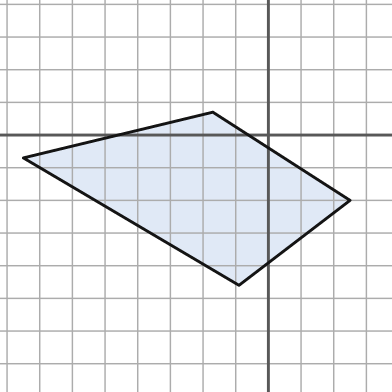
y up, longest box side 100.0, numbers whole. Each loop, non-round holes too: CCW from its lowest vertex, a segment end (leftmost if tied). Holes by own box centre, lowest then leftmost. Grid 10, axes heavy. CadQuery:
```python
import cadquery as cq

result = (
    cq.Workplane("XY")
    .moveTo(-9.0, -46.0)
    .lineTo(25.0, -20.0)
    .lineTo(-17.0, 7.0)
    .lineTo(-75.0, -7.0)
    .close()
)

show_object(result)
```